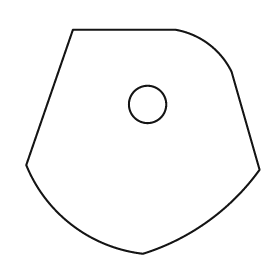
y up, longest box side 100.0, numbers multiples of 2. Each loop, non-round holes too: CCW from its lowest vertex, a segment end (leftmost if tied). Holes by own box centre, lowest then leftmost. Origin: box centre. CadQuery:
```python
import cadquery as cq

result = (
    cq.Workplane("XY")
    .moveTo(0.0, -48.0)
    .threePointArc((28.0, -34.0), (50.0, -12.0))
    .lineTo(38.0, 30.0)
    .threePointArc((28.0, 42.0), (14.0, 48.0))
    .lineTo(-30.0, 48.0)
    .lineTo(-50.0, -10.0)
    .threePointArc((-30.0, -36.0), (0.0, -48.0))
    .close()
    .moveTo(2.0, 16.0)
    .circle(8.0)
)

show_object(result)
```